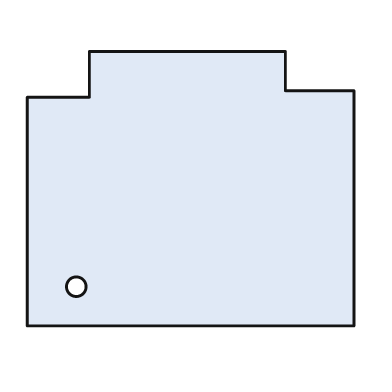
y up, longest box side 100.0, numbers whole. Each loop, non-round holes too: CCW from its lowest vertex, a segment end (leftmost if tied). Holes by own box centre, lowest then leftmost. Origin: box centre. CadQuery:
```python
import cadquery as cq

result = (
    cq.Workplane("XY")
    .moveTo(-50.0, -42.0)
    .lineTo(50.0, -42.0)
    .lineTo(50.0, 30.0)
    .lineTo(29.0, 30.0)
    .lineTo(29.0, 42.0)
    .lineTo(-31.0, 42.0)
    .lineTo(-31.0, 28.0)
    .lineTo(-50.0, 28.0)
    .close()
    .moveTo(-35.0, -30.0)
    .circle(3.0)
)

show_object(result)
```